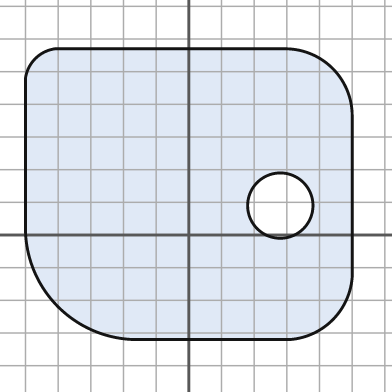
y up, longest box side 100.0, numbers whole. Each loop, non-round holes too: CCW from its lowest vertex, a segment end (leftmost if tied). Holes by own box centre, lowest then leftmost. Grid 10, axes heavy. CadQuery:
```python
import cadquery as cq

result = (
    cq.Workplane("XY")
    .moveTo(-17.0, -32.0)
    .lineTo(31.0, -32.0)
    .threePointArc((44.0, -26.0), (50.0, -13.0))
    .lineTo(50.0, 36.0)
    .threePointArc((44.0, 51.0), (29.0, 57.0))
    .lineTo(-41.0, 57.0)
    .threePointArc((-47.0, 54.0), (-50.0, 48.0))
    .lineTo(-50.0, 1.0)
    .threePointArc((-40.0, -22.0), (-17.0, -32.0))
    .close()
    .moveTo(28.0, 9.0)
    .circle(10.0)
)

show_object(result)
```